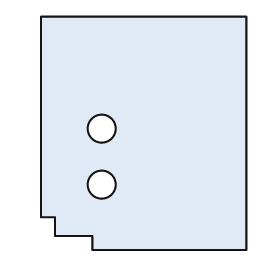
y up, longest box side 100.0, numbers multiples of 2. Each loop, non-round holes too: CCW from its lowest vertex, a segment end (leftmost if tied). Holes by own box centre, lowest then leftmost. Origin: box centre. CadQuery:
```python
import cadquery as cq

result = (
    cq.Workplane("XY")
    .moveTo(-22.0, -50.0)
    .lineTo(44.0, -50.0)
    .lineTo(44.0, 50.0)
    .lineTo(-44.0, 50.0)
    .lineTo(-44.0, -36.0)
    .lineTo(-38.0, -36.0)
    .lineTo(-38.0, -44.0)
    .lineTo(-22.0, -44.0)
    .close()
    .moveTo(-18.0, -22.0)
    .circle(6.0)
    .moveTo(-18.0, 2.0)
    .circle(6.0)
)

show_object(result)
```